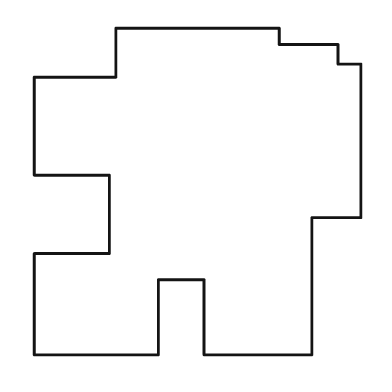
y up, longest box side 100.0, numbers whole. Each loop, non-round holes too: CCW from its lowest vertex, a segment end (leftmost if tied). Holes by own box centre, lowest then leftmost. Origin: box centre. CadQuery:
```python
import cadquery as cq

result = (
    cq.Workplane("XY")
    .moveTo(-50.0, -50.0)
    .lineTo(-12.0, -50.0)
    .lineTo(-12.0, -27.0)
    .lineTo(2.0, -27.0)
    .lineTo(2.0, -50.0)
    .lineTo(35.0, -50.0)
    .lineTo(35.0, -8.0)
    .lineTo(50.0, -8.0)
    .lineTo(50.0, 39.0)
    .lineTo(43.0, 39.0)
    .lineTo(43.0, 45.0)
    .lineTo(25.0, 45.0)
    .lineTo(25.0, 50.0)
    .lineTo(-25.0, 50.0)
    .lineTo(-25.0, 35.0)
    .lineTo(-50.0, 35.0)
    .lineTo(-50.0, 5.0)
    .lineTo(-27.0, 5.0)
    .lineTo(-27.0, -19.0)
    .lineTo(-50.0, -19.0)
    .close()
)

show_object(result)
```